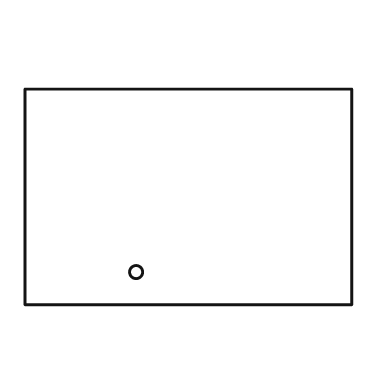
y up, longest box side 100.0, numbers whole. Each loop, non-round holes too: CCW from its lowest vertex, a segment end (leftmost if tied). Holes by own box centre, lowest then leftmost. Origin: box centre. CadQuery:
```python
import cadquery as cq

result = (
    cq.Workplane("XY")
    .moveTo(-50.0, -33.0)
    .lineTo(50.0, -33.0)
    .lineTo(50.0, 33.0)
    .lineTo(-50.0, 33.0)
    .close()
    .moveTo(-16.0, -23.0)
    .circle(2.0)
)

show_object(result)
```